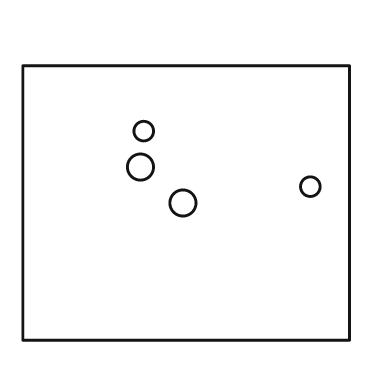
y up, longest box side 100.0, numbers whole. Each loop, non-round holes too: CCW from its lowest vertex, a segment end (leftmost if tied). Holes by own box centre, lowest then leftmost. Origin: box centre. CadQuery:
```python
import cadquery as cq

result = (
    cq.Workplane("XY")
    .moveTo(-50.0, -42.0)
    .lineTo(50.0, -42.0)
    .lineTo(50.0, 42.0)
    .lineTo(-50.0, 42.0)
    .close()
    .moveTo(-1.0, 0.0)
    .circle(4.0)
    .moveTo(38.0, 5.0)
    .circle(3.0)
    .moveTo(-14.0, 11.0)
    .circle(4.0)
    .moveTo(-13.0, 22.0)
    .circle(3.0)
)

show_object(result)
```